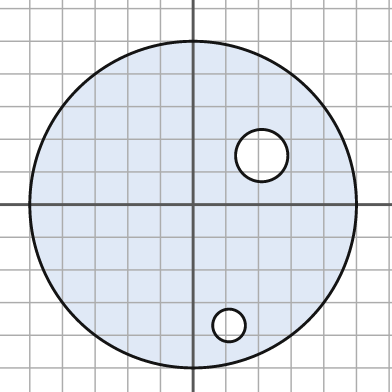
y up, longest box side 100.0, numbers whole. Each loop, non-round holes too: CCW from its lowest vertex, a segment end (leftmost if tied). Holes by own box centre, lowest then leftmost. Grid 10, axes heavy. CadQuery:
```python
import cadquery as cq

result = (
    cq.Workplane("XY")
    .moveTo(0.0, 0.0)
    .circle(50.0)
    .moveTo(11.0, -37.0)
    .circle(5.0)
    .moveTo(21.0, 15.0)
    .circle(8.0)
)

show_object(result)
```